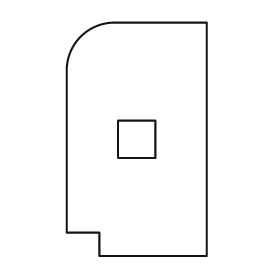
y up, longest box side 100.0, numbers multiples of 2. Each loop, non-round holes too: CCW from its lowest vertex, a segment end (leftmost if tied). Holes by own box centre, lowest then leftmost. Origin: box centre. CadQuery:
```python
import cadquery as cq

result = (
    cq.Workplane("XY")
    .moveTo(-16.0, -50.0)
    .lineTo(30.0, -50.0)
    .lineTo(30.0, 50.0)
    .lineTo(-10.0, 50.0)
    .threePointArc((-24.0, 44.0), (-30.0, 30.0))
    .lineTo(-30.0, -40.0)
    .lineTo(-16.0, -40.0)
    .close()
    .moveTo(-8.0, -8.0)
    .lineTo(8.0, -8.0)
    .lineTo(8.0, 8.0)
    .lineTo(-8.0, 8.0)
    .close()
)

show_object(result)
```